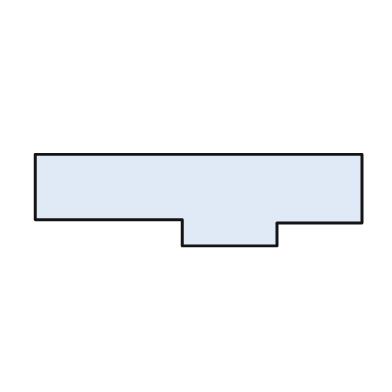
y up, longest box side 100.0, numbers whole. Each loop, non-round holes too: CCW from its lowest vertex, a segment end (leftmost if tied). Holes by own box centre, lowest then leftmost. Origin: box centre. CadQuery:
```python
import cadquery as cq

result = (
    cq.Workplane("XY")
    .moveTo(-5.0, -14.0)
    .lineTo(24.0, -14.0)
    .lineTo(24.0, -7.0)
    .lineTo(50.0, -7.0)
    .lineTo(50.0, 14.0)
    .lineTo(-50.0, 14.0)
    .lineTo(-50.0, -6.0)
    .lineTo(-5.0, -6.0)
    .close()
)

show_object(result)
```